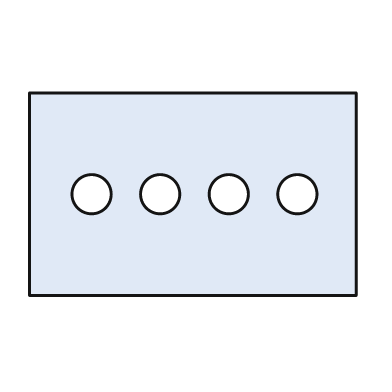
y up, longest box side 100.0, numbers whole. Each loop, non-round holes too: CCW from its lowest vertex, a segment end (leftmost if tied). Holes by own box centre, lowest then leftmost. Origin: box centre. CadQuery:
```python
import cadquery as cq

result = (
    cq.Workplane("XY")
    .moveTo(-50.0, -31.0)
    .lineTo(50.0, -31.0)
    .lineTo(50.0, 31.0)
    .lineTo(-50.0, 31.0)
    .close()
    .moveTo(-31.0, 0.0)
    .circle(6.0)
    .moveTo(-10.0, 0.0)
    .circle(6.0)
    .moveTo(11.0, 0.0)
    .circle(6.0)
    .moveTo(32.0, 0.0)
    .circle(6.0)
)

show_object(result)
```